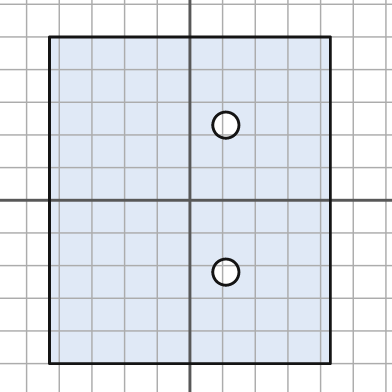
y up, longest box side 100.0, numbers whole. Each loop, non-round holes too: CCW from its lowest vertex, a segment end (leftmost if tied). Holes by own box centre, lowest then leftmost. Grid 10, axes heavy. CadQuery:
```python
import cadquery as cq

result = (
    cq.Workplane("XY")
    .moveTo(-43.0, -50.0)
    .lineTo(43.0, -50.0)
    .lineTo(43.0, 50.0)
    .lineTo(-43.0, 50.0)
    .close()
    .moveTo(11.0, -22.0)
    .circle(4.0)
    .moveTo(11.0, 23.0)
    .circle(4.0)
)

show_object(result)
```